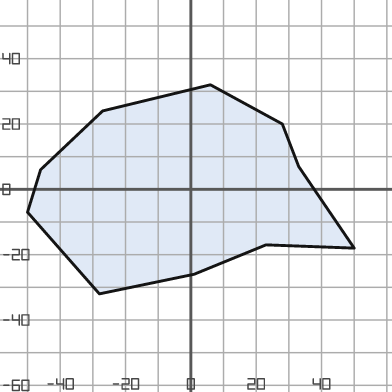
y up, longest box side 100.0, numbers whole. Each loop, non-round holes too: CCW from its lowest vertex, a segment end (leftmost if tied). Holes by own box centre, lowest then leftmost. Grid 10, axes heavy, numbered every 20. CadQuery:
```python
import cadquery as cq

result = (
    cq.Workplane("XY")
    .moveTo(-28.0, -32.0)
    .lineTo(1.0, -26.0)
    .lineTo(23.0, -17.0)
    .lineTo(50.0, -18.0)
    .lineTo(33.0, 7.0)
    .lineTo(28.0, 20.0)
    .lineTo(6.0, 32.0)
    .lineTo(-27.0, 24.0)
    .lineTo(-46.0, 6.0)
    .lineTo(-50.0, -7.0)
    .close()
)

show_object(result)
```